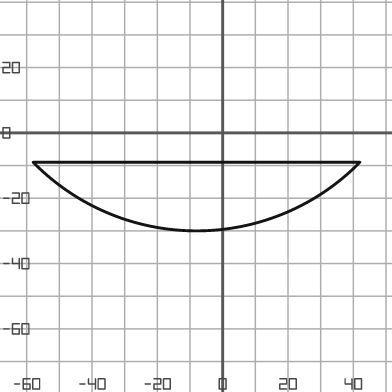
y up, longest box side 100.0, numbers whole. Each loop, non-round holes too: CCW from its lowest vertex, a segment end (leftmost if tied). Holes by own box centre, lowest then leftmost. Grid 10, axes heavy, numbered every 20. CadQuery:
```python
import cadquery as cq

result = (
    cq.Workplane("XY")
    .moveTo(-58.0, -9.0)
    .threePointArc((-8.0, -30.0), (42.0, -9.0))
    .close()
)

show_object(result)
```